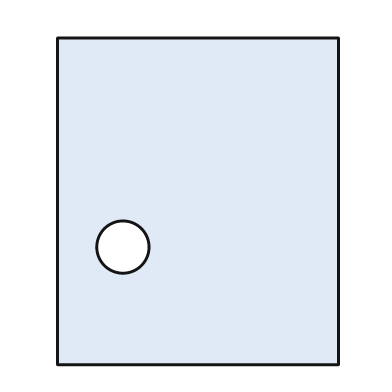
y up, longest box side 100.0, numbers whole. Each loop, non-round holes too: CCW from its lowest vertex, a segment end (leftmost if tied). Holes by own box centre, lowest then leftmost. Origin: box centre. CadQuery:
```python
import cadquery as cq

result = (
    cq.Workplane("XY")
    .moveTo(-43.0, -50.0)
    .lineTo(43.0, -50.0)
    .lineTo(43.0, 50.0)
    .lineTo(-43.0, 50.0)
    .close()
    .moveTo(-23.0, -14.0)
    .circle(8.0)
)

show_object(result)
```